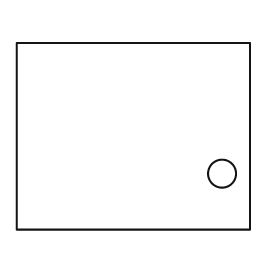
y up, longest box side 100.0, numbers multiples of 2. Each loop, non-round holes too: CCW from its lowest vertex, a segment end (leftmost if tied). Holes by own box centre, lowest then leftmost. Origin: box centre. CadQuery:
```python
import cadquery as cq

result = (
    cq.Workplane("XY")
    .moveTo(-50.0, -40.0)
    .lineTo(50.0, -40.0)
    .lineTo(50.0, 40.0)
    .lineTo(-50.0, 40.0)
    .close()
    .moveTo(38.0, -16.0)
    .circle(6.0)
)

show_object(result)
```